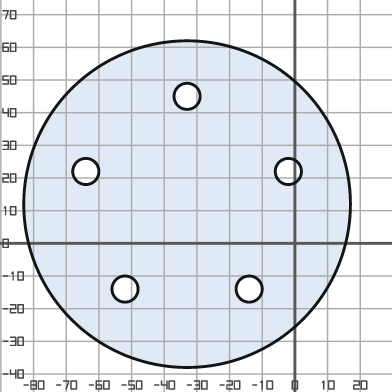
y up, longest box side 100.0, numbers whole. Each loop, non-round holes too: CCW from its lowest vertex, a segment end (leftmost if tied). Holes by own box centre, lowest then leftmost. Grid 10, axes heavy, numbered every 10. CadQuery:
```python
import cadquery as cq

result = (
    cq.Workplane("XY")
    .moveTo(-33.0, 12.0)
    .circle(50.0)
    .moveTo(-52.0, -14.0)
    .circle(4.0)
    .moveTo(-14.0, -14.0)
    .circle(4.0)
    .moveTo(-64.0, 22.0)
    .circle(4.0)
    .moveTo(-2.0, 22.0)
    .circle(4.0)
    .moveTo(-33.0, 45.0)
    .circle(4.0)
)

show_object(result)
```